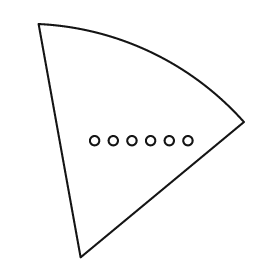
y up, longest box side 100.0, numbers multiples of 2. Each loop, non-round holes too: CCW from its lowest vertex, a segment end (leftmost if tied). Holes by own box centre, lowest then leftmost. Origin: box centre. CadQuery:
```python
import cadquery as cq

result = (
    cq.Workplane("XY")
    .moveTo(-26.0, -50.0)
    .lineTo(44.0, 8.0)
    .threePointArc((4.0, 38.0), (-44.0, 50.0))
    .close()
    .moveTo(-20.0, 0.0)
    .circle(2.0)
    .moveTo(-12.0, 0.0)
    .circle(2.0)
    .moveTo(-4.0, 0.0)
    .circle(2.0)
    .moveTo(4.0, 0.0)
    .circle(2.0)
    .moveTo(12.0, 0.0)
    .circle(2.0)
    .moveTo(20.0, 0.0)
    .circle(2.0)
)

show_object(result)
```